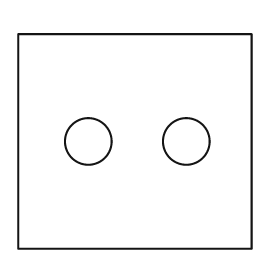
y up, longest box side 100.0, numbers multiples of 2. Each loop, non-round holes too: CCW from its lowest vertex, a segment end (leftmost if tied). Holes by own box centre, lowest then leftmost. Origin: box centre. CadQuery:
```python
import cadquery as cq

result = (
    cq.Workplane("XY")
    .moveTo(-50.0, -46.0)
    .lineTo(50.0, -46.0)
    .lineTo(50.0, 46.0)
    .lineTo(-50.0, 46.0)
    .close()
    .moveTo(-20.0, 0.0)
    .circle(10.0)
    .moveTo(22.0, 0.0)
    .circle(10.0)
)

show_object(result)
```